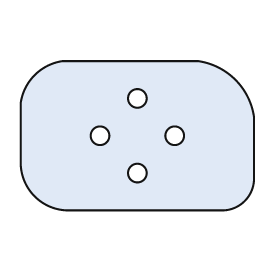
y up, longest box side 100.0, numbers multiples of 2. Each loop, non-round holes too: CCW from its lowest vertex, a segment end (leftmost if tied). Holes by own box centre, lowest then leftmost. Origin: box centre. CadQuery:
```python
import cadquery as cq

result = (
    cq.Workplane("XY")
    .moveTo(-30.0, -32.0)
    .lineTo(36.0, -32.0)
    .threePointArc((46.0, -28.0), (50.0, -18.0))
    .lineTo(50.0, 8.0)
    .threePointArc((42.0, 24.0), (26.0, 32.0))
    .lineTo(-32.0, 32.0)
    .threePointArc((-44.0, 26.0), (-50.0, 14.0))
    .lineTo(-50.0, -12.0)
    .threePointArc((-44.0, -26.0), (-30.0, -32.0))
    .close()
    .moveTo(0.0, -16.0)
    .circle(4.0)
    .moveTo(-16.0, 0.0)
    .circle(4.0)
    .moveTo(16.0, 0.0)
    .circle(4.0)
    .moveTo(0.0, 16.0)
    .circle(4.0)
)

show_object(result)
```